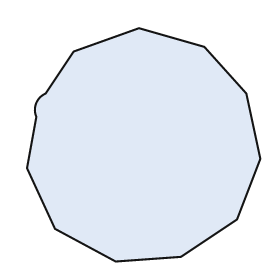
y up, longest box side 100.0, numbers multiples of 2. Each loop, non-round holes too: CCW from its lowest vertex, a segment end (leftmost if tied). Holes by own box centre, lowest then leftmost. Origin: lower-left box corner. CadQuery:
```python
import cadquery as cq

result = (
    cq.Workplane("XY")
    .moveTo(38.0, 0.0)
    .lineTo(66.0, 2.0)
    .lineTo(90.0, 18.0)
    .lineTo(100.0, 44.0)
    .lineTo(94.0, 72.0)
    .lineTo(76.0, 92.0)
    .lineTo(48.0, 100.0)
    .lineTo(20.0, 90.0)
    .lineTo(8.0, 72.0)
    .threePointArc((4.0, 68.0), (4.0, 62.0))
    .lineTo(0.0, 40.0)
    .lineTo(12.0, 14.0)
    .close()
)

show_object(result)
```